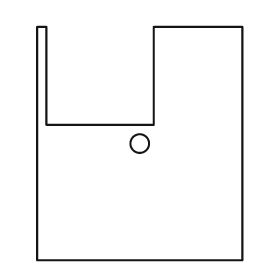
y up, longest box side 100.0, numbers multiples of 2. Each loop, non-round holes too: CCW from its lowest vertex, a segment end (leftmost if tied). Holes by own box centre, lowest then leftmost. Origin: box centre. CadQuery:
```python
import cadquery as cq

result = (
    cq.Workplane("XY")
    .moveTo(-44.0, -50.0)
    .lineTo(44.0, -50.0)
    .lineTo(44.0, 50.0)
    .lineTo(6.0, 50.0)
    .lineTo(6.0, 8.0)
    .lineTo(-40.0, 8.0)
    .lineTo(-40.0, 50.0)
    .lineTo(-44.0, 50.0)
    .close()
    .moveTo(0.0, 0.0)
    .circle(4.0)
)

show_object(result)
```